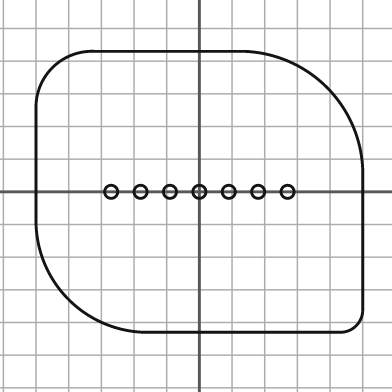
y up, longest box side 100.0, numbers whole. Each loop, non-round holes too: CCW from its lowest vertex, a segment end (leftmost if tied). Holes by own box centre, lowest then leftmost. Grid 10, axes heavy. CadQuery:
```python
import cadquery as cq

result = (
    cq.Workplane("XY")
    .moveTo(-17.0, -43.0)
    .lineTo(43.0, -43.0)
    .threePointArc((48.0, -41.0), (50.0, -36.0))
    .lineTo(50.0, 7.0)
    .threePointArc((39.0, 32.0), (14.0, 43.0))
    .lineTo(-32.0, 43.0)
    .threePointArc((-45.0, 38.0), (-50.0, 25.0))
    .lineTo(-50.0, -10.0)
    .threePointArc((-40.0, -33.0), (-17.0, -43.0))
    .close()
    .moveTo(-27.0, 0.0)
    .circle(2.0)
    .moveTo(-18.0, 0.0)
    .circle(2.0)
    .moveTo(-9.0, 0.0)
    .circle(2.0)
    .moveTo(0.0, 0.0)
    .circle(2.0)
    .moveTo(9.0, 0.0)
    .circle(2.0)
    .moveTo(18.0, 0.0)
    .circle(2.0)
    .moveTo(27.0, 0.0)
    .circle(2.0)
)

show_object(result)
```